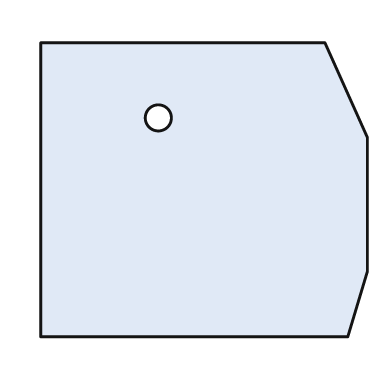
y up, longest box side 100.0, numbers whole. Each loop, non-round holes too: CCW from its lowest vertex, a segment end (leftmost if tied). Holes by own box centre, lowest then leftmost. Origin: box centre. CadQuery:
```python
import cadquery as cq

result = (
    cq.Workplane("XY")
    .moveTo(-50.0, -45.0)
    .lineTo(44.0, -45.0)
    .lineTo(50.0, -25.0)
    .lineTo(50.0, 16.0)
    .lineTo(37.0, 45.0)
    .lineTo(-50.0, 45.0)
    .close()
    .moveTo(-14.0, 22.0)
    .circle(4.0)
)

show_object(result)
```